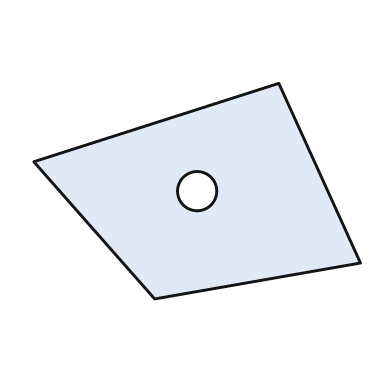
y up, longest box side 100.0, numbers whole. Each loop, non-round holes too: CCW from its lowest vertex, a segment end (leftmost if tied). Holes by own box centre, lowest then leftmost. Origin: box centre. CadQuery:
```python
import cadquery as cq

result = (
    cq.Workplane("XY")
    .moveTo(-13.0, -33.0)
    .lineTo(50.0, -22.0)
    .lineTo(25.0, 33.0)
    .lineTo(-50.0, 9.0)
    .close()
    .moveTo(0.0, 0.0)
    .circle(6.0)
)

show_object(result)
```